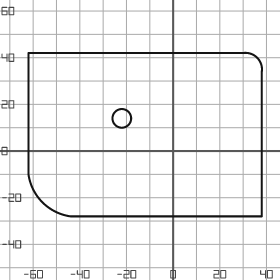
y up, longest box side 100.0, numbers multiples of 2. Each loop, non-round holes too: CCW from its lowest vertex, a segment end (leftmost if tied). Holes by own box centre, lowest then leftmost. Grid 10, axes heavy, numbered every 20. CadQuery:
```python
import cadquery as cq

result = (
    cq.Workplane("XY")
    .moveTo(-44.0, -28.0)
    .lineTo(38.0, -28.0)
    .lineTo(38.0, 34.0)
    .threePointArc((36.0, 40.0), (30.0, 42.0))
    .lineTo(-62.0, 42.0)
    .lineTo(-62.0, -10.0)
    .threePointArc((-56.0, -22.0), (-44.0, -28.0))
    .close()
    .moveTo(-22.0, 14.0)
    .circle(4.0)
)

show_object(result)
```